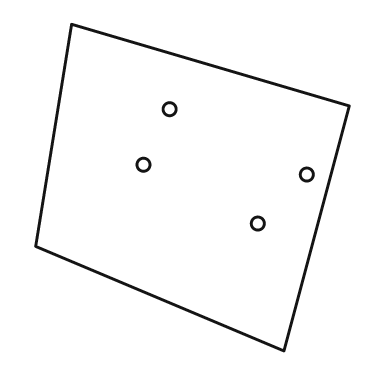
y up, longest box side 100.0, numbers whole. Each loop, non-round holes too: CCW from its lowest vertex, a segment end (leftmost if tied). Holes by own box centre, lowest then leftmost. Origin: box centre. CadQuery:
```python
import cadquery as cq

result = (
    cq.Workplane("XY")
    .moveTo(28.0, -50.0)
    .lineTo(48.0, 25.0)
    .lineTo(-37.0, 50.0)
    .lineTo(-48.0, -18.0)
    .close()
    .moveTo(20.0, -11.0)
    .circle(2.0)
    .moveTo(35.0, 4.0)
    .circle(2.0)
    .moveTo(-15.0, 7.0)
    .circle(2.0)
    .moveTo(-7.0, 24.0)
    .circle(2.0)
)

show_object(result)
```